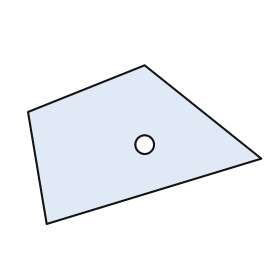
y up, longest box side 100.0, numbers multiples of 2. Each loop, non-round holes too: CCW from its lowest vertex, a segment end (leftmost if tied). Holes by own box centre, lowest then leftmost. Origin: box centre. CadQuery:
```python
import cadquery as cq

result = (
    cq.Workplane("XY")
    .moveTo(-42.0, -34.0)
    .lineTo(50.0, -6.0)
    .lineTo(0.0, 34.0)
    .lineTo(-50.0, 14.0)
    .close()
    .moveTo(0.0, 0.0)
    .circle(4.0)
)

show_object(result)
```